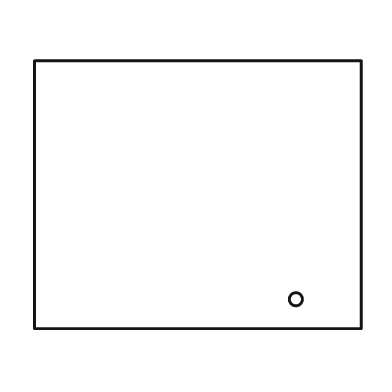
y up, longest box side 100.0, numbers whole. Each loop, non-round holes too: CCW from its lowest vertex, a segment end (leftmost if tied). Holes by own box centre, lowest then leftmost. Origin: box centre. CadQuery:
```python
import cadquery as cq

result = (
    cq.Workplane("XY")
    .moveTo(-50.0, -41.0)
    .lineTo(50.0, -41.0)
    .lineTo(50.0, 41.0)
    .lineTo(-50.0, 41.0)
    .close()
    .moveTo(30.0, -32.0)
    .circle(2.0)
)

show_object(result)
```